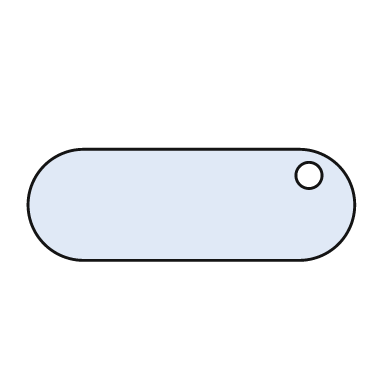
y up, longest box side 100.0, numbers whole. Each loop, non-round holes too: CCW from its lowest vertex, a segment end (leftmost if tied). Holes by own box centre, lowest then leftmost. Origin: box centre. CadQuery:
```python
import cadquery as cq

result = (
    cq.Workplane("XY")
    .moveTo(-33.0, -17.0)
    .lineTo(33.0, -17.0)
    .threePointArc((50.0, 0.0), (33.0, 17.0))
    .lineTo(-33.0, 17.0)
    .threePointArc((-50.0, 0.0), (-33.0, -17.0))
    .close()
    .moveTo(36.0, 9.0)
    .circle(4.0)
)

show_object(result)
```